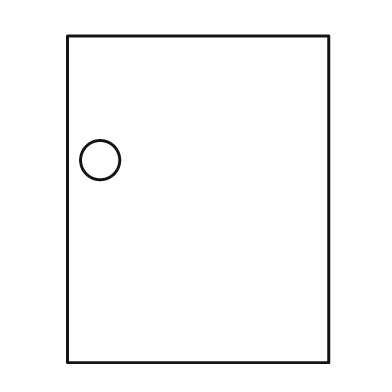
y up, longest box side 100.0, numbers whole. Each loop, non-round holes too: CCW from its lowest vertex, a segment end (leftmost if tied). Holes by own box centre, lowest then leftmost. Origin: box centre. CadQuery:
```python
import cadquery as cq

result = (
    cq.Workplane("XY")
    .moveTo(-40.0, -50.0)
    .lineTo(40.0, -50.0)
    .lineTo(40.0, 50.0)
    .lineTo(-40.0, 50.0)
    .close()
    .moveTo(-30.0, 12.0)
    .circle(6.0)
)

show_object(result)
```